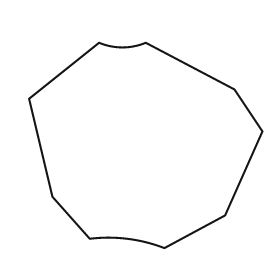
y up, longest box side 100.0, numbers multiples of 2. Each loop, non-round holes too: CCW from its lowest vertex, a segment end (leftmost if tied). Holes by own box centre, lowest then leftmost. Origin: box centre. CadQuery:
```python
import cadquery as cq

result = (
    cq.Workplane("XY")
    .moveTo(8.0, -44.0)
    .lineTo(34.0, -30.0)
    .lineTo(50.0, 6.0)
    .lineTo(38.0, 24.0)
    .lineTo(0.0, 44.0)
    .threePointArc((-10.0, 42.0), (-20.0, 44.0))
    .lineTo(-50.0, 20.0)
    .lineTo(-40.0, -22.0)
    .lineTo(-24.0, -40.0)
    .threePointArc((-8.0, -40.0), (8.0, -44.0))
    .close()
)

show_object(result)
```